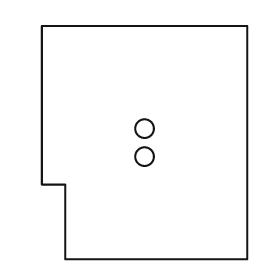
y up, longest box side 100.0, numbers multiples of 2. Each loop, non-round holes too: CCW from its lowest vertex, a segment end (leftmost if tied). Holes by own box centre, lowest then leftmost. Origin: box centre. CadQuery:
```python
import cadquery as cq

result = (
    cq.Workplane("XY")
    .moveTo(-34.0, -50.0)
    .lineTo(44.0, -50.0)
    .lineTo(44.0, 50.0)
    .lineTo(-44.0, 50.0)
    .lineTo(-44.0, -18.0)
    .lineTo(-34.0, -18.0)
    .close()
    .moveTo(0.0, -6.0)
    .circle(4.0)
    .moveTo(0.0, 6.0)
    .circle(4.0)
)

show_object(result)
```